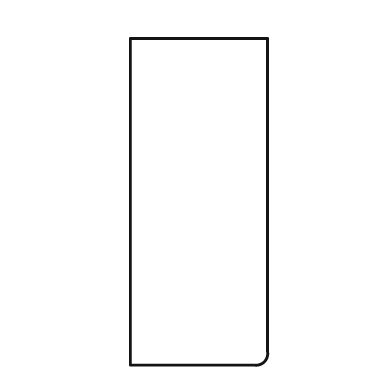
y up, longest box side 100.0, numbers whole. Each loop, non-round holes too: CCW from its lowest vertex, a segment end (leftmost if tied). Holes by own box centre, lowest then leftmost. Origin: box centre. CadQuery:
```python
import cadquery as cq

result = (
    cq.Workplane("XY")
    .moveTo(-21.0, -50.0)
    .lineTo(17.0, -50.0)
    .threePointArc((20.0, -49.0), (21.0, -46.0))
    .lineTo(21.0, 50.0)
    .lineTo(-21.0, 50.0)
    .close()
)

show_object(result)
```